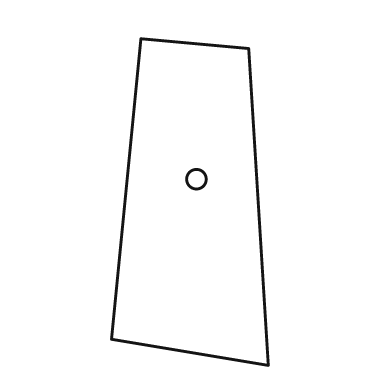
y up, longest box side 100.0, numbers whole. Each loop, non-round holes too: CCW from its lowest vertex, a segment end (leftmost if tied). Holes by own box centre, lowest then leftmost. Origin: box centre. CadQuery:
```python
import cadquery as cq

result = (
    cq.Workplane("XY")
    .moveTo(24.0, -50.0)
    .lineTo(18.0, 47.0)
    .lineTo(-15.0, 50.0)
    .lineTo(-24.0, -42.0)
    .close()
    .moveTo(2.0, 7.0)
    .circle(3.0)
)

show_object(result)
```